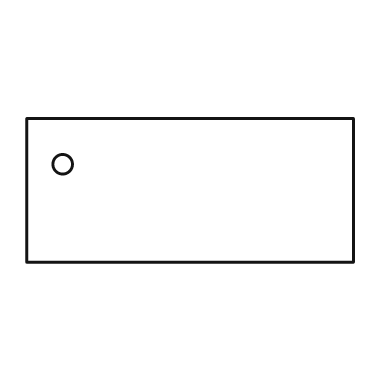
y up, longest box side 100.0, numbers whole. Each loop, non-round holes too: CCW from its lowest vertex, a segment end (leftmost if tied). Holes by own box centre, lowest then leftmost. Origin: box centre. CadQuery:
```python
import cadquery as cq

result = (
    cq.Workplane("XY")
    .moveTo(-50.0, -22.0)
    .lineTo(50.0, -22.0)
    .lineTo(50.0, 22.0)
    .lineTo(-50.0, 22.0)
    .close()
    .moveTo(-39.0, 8.0)
    .circle(3.0)
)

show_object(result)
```